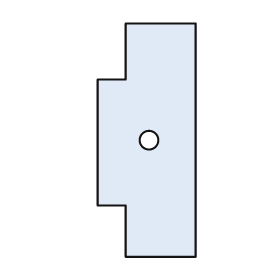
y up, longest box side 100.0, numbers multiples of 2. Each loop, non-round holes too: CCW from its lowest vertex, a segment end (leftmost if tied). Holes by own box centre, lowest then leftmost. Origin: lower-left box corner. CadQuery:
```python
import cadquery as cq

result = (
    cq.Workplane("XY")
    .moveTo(12.0, 0.0)
    .lineTo(42.0, 0.0)
    .lineTo(42.0, 100.0)
    .lineTo(12.0, 100.0)
    .lineTo(12.0, 76.0)
    .lineTo(0.0, 76.0)
    .lineTo(0.0, 22.0)
    .lineTo(12.0, 22.0)
    .close()
    .moveTo(22.0, 50.0)
    .circle(4.0)
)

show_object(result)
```